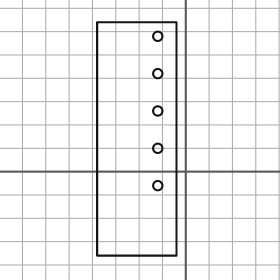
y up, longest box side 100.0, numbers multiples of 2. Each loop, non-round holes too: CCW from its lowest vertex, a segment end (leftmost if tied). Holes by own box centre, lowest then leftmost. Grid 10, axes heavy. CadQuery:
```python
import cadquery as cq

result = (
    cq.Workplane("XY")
    .moveTo(-38.0, -36.0)
    .lineTo(-4.0, -36.0)
    .lineTo(-4.0, 64.0)
    .lineTo(-38.0, 64.0)
    .close()
    .moveTo(-12.0, -6.0)
    .circle(2.0)
    .moveTo(-12.0, 10.0)
    .circle(2.0)
    .moveTo(-12.0, 26.0)
    .circle(2.0)
    .moveTo(-12.0, 42.0)
    .circle(2.0)
    .moveTo(-12.0, 58.0)
    .circle(2.0)
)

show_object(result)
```